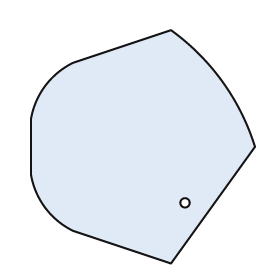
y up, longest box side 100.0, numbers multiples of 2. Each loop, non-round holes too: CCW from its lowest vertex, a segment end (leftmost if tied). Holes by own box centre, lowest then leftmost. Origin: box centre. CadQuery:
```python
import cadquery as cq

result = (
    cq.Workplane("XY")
    .moveTo(12.0, -50.0)
    .lineTo(48.0, 0.0)
    .threePointArc((34.0, 28.0), (12.0, 50.0))
    .lineTo(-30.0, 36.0)
    .threePointArc((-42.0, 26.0), (-48.0, 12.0))
    .lineTo(-48.0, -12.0)
    .threePointArc((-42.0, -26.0), (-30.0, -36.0))
    .close()
    .moveTo(18.0, -24.0)
    .circle(2.0)
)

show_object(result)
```